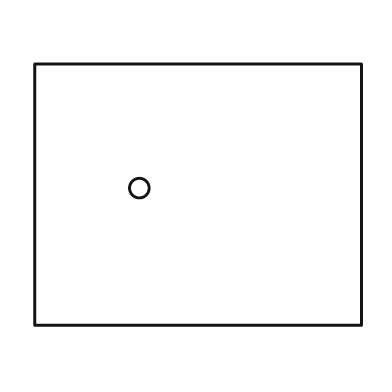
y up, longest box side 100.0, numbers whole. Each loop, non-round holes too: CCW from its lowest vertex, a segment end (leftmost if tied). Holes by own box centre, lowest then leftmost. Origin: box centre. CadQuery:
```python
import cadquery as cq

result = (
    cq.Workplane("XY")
    .moveTo(-50.0, -40.0)
    .lineTo(50.0, -40.0)
    .lineTo(50.0, 40.0)
    .lineTo(-50.0, 40.0)
    .close()
    .moveTo(-18.0, 2.0)
    .circle(3.0)
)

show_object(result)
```